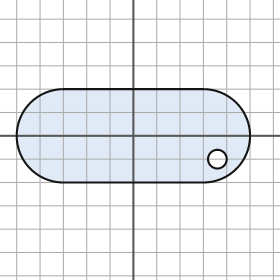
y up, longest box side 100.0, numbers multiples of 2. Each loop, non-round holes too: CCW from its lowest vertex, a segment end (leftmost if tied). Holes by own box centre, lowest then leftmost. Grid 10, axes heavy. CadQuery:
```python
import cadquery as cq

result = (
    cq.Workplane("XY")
    .moveTo(-30.0, -20.0)
    .lineTo(30.0, -20.0)
    .threePointArc((50.0, 0.0), (30.0, 20.0))
    .lineTo(-30.0, 20.0)
    .threePointArc((-50.0, 0.0), (-30.0, -20.0))
    .close()
    .moveTo(36.0, -10.0)
    .circle(4.0)
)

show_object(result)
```